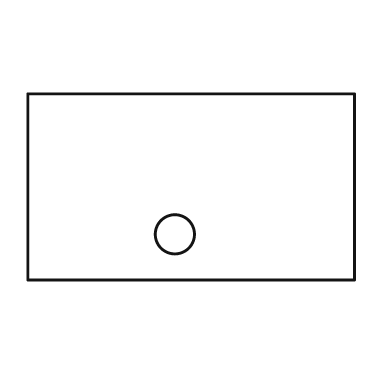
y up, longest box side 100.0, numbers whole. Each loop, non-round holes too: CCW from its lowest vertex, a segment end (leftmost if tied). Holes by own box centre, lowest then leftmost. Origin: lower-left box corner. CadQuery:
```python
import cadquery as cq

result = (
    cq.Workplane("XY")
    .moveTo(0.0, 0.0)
    .lineTo(100.0, 0.0)
    .lineTo(100.0, 57.0)
    .lineTo(0.0, 57.0)
    .close()
    .moveTo(45.0, 14.0)
    .circle(6.0)
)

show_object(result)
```